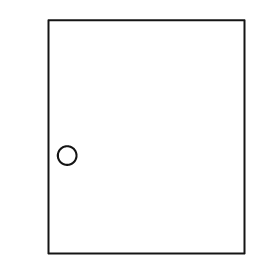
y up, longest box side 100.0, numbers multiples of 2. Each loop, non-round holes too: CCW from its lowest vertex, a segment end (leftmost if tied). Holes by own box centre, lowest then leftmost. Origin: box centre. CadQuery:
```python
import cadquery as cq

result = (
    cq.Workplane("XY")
    .moveTo(-42.0, -50.0)
    .lineTo(42.0, -50.0)
    .lineTo(42.0, 50.0)
    .lineTo(-42.0, 50.0)
    .close()
    .moveTo(-34.0, -8.0)
    .circle(4.0)
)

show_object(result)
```